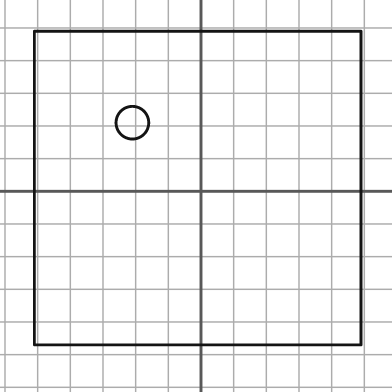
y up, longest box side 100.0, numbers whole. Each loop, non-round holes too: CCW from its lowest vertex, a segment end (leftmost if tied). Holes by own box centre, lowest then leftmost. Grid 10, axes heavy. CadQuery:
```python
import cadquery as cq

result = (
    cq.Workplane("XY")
    .moveTo(-51.0, -47.0)
    .lineTo(49.0, -47.0)
    .lineTo(49.0, 49.0)
    .lineTo(-51.0, 49.0)
    .close()
    .moveTo(-21.0, 21.0)
    .circle(5.0)
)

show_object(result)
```